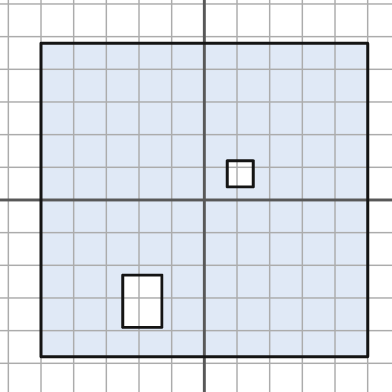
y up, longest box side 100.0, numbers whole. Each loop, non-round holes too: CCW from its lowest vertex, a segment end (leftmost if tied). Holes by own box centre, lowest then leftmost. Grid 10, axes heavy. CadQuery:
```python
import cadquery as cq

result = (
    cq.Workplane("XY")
    .moveTo(-50.0, -48.0)
    .lineTo(50.0, -48.0)
    .lineTo(50.0, 48.0)
    .lineTo(-50.0, 48.0)
    .close()
    .moveTo(-25.0, -39.0)
    .lineTo(-13.0, -39.0)
    .lineTo(-13.0, -23.0)
    .lineTo(-25.0, -23.0)
    .close()
    .moveTo(7.0, 4.0)
    .lineTo(15.0, 4.0)
    .lineTo(15.0, 12.0)
    .lineTo(7.0, 12.0)
    .close()
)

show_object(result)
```